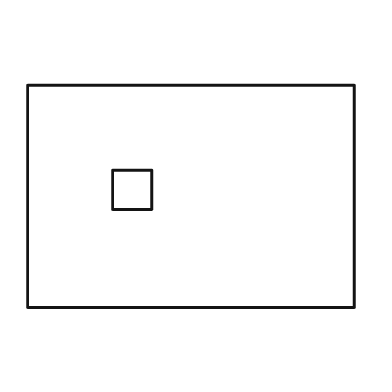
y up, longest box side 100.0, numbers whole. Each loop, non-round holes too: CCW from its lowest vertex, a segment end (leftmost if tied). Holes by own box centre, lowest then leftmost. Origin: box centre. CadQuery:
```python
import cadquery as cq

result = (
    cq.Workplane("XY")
    .moveTo(-50.0, -34.0)
    .lineTo(50.0, -34.0)
    .lineTo(50.0, 34.0)
    .lineTo(-50.0, 34.0)
    .close()
    .moveTo(-24.0, -4.0)
    .lineTo(-12.0, -4.0)
    .lineTo(-12.0, 8.0)
    .lineTo(-24.0, 8.0)
    .close()
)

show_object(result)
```